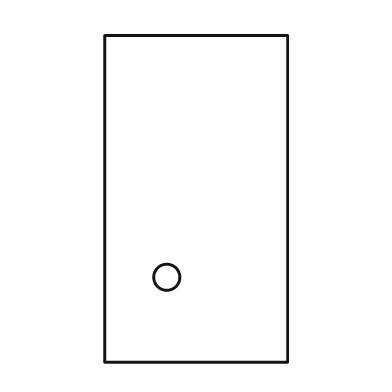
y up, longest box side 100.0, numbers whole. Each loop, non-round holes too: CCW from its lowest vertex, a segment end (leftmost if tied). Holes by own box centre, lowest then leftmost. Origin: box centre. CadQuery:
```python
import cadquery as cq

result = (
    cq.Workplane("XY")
    .moveTo(-28.0, -50.0)
    .lineTo(28.0, -50.0)
    .lineTo(28.0, 50.0)
    .lineTo(-28.0, 50.0)
    .close()
    .moveTo(-9.0, -24.0)
    .circle(4.0)
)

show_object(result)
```